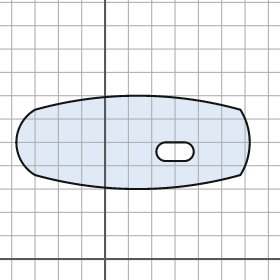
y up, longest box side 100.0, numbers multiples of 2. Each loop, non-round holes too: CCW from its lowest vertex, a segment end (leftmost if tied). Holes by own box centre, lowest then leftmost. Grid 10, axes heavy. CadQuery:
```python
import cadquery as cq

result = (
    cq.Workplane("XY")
    .moveTo(-30.0, 36.0)
    .threePointArc((14.0, 30.0), (58.0, 36.0))
    .threePointArc((62.0, 50.0), (58.0, 64.0))
    .threePointArc((14.0, 70.0), (-30.0, 64.0))
    .threePointArc((-38.0, 50.0), (-30.0, 36.0))
    .close()
    .moveTo(26.0, 42.0)
    .lineTo(34.0, 42.0)
    .threePointArc((38.0, 46.0), (34.0, 50.0))
    .lineTo(26.0, 50.0)
    .threePointArc((22.0, 46.0), (26.0, 42.0))
    .close()
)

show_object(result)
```